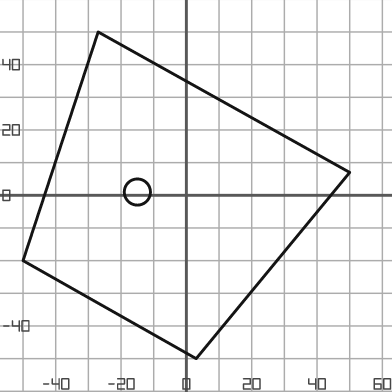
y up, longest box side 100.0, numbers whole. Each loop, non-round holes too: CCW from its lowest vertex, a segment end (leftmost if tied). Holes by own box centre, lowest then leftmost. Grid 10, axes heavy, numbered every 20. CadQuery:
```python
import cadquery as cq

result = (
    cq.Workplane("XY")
    .moveTo(3.0, -50.0)
    .lineTo(50.0, 7.0)
    .lineTo(-27.0, 50.0)
    .lineTo(-50.0, -20.0)
    .close()
    .moveTo(-15.0, 1.0)
    .circle(4.0)
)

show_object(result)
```